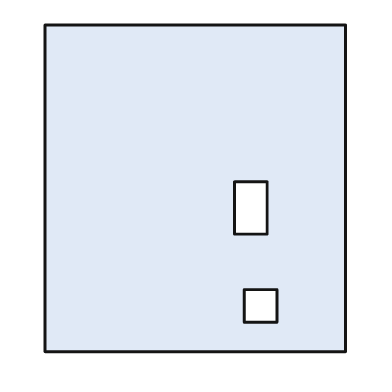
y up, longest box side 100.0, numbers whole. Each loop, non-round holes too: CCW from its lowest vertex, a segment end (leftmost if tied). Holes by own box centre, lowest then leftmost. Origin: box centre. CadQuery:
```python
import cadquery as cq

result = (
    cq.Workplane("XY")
    .moveTo(-46.0, -50.0)
    .lineTo(46.0, -50.0)
    .lineTo(46.0, 50.0)
    .lineTo(-46.0, 50.0)
    .close()
    .moveTo(15.0, -41.0)
    .lineTo(25.0, -41.0)
    .lineTo(25.0, -31.0)
    .lineTo(15.0, -31.0)
    .close()
    .moveTo(12.0, -14.0)
    .lineTo(22.0, -14.0)
    .lineTo(22.0, 2.0)
    .lineTo(12.0, 2.0)
    .close()
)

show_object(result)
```